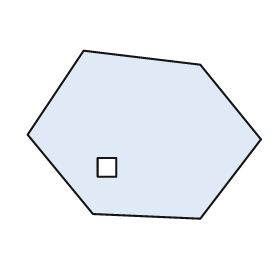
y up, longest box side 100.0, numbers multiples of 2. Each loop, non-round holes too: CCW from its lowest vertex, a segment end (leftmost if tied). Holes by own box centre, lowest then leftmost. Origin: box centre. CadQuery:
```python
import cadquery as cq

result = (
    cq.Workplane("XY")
    .moveTo(24.0, -36.0)
    .lineTo(50.0, -2.0)
    .lineTo(24.0, 30.0)
    .lineTo(-26.0, 36.0)
    .lineTo(-50.0, 0.0)
    .lineTo(-22.0, -34.0)
    .close()
    .moveTo(-20.0, -18.0)
    .lineTo(-12.0, -18.0)
    .lineTo(-12.0, -10.0)
    .lineTo(-20.0, -10.0)
    .close()
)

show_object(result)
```